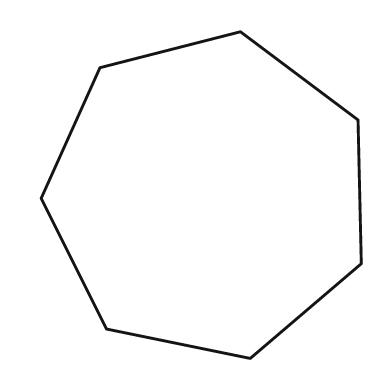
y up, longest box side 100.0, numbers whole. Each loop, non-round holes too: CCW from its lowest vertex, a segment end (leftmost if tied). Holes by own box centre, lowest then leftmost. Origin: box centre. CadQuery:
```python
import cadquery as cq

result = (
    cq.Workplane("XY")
    .moveTo(15.0, -50.0)
    .lineTo(49.0, -21.0)
    .lineTo(48.0, 23.0)
    .lineTo(12.0, 50.0)
    .lineTo(-31.0, 39.0)
    .lineTo(-49.0, -1.0)
    .lineTo(-29.0, -41.0)
    .close()
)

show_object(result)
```